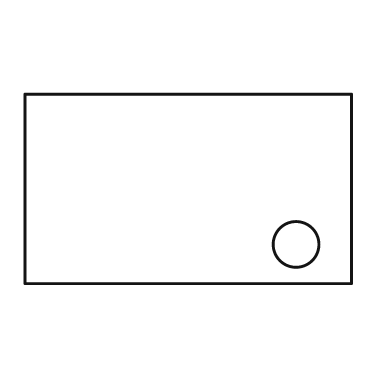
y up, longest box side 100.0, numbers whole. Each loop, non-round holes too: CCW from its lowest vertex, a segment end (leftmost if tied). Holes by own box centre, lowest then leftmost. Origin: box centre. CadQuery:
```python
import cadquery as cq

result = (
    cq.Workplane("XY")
    .moveTo(-50.0, -29.0)
    .lineTo(50.0, -29.0)
    .lineTo(50.0, 29.0)
    .lineTo(-50.0, 29.0)
    .close()
    .moveTo(33.0, -17.0)
    .circle(7.0)
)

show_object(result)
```